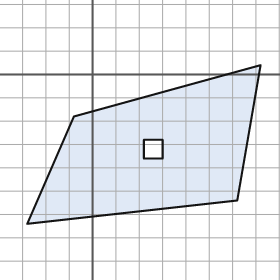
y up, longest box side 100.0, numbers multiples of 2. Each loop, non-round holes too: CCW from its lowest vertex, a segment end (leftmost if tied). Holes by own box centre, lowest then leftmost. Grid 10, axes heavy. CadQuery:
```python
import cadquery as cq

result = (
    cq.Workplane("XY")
    .moveTo(-28.0, -64.0)
    .lineTo(62.0, -54.0)
    .lineTo(72.0, 4.0)
    .lineTo(-8.0, -18.0)
    .close()
    .moveTo(22.0, -36.0)
    .lineTo(30.0, -36.0)
    .lineTo(30.0, -28.0)
    .lineTo(22.0, -28.0)
    .close()
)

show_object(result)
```